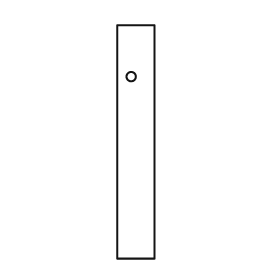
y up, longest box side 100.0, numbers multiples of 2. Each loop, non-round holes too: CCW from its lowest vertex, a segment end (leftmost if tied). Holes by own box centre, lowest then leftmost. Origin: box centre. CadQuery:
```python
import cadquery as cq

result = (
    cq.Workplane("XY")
    .moveTo(-8.0, -50.0)
    .lineTo(8.0, -50.0)
    .lineTo(8.0, 50.0)
    .lineTo(-8.0, 50.0)
    .close()
    .moveTo(-2.0, 28.0)
    .circle(2.0)
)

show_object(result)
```